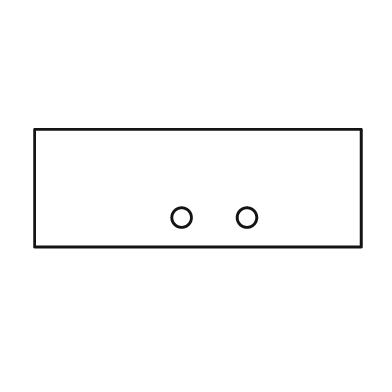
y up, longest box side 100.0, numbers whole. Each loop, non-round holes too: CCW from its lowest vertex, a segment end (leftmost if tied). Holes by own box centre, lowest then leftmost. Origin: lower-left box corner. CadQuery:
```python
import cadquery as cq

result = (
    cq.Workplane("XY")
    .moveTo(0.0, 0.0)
    .lineTo(100.0, 0.0)
    .lineTo(100.0, 36.0)
    .lineTo(0.0, 36.0)
    .close()
    .moveTo(45.0, 9.0)
    .circle(3.0)
    .moveTo(65.0, 9.0)
    .circle(3.0)
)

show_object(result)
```